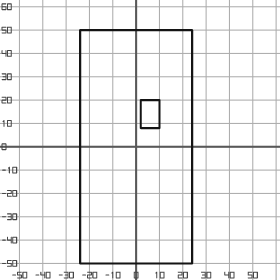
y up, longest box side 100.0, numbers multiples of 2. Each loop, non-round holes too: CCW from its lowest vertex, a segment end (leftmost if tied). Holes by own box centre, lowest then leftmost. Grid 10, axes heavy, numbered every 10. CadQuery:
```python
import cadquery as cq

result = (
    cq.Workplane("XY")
    .moveTo(-24.0, -50.0)
    .lineTo(24.0, -50.0)
    .lineTo(24.0, 50.0)
    .lineTo(-24.0, 50.0)
    .close()
    .moveTo(2.0, 8.0)
    .lineTo(10.0, 8.0)
    .lineTo(10.0, 20.0)
    .lineTo(2.0, 20.0)
    .close()
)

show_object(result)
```